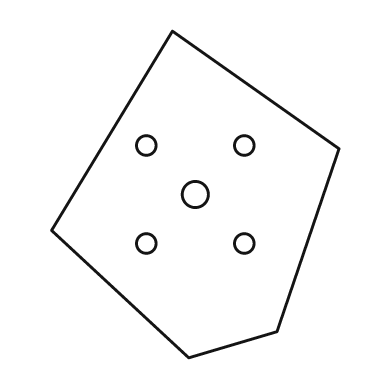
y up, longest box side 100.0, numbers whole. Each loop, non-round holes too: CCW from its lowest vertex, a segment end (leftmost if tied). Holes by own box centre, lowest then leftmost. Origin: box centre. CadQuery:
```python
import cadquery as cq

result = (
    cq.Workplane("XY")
    .moveTo(-2.0, -50.0)
    .lineTo(25.0, -42.0)
    .lineTo(44.0, 14.0)
    .lineTo(-7.0, 50.0)
    .lineTo(-44.0, -11.0)
    .close()
    .moveTo(-15.0, -15.0)
    .circle(3.0)
    .moveTo(15.0, -15.0)
    .circle(3.0)
    .moveTo(0.0, 0.0)
    .circle(4.0)
    .moveTo(-15.0, 15.0)
    .circle(3.0)
    .moveTo(15.0, 15.0)
    .circle(3.0)
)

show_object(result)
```